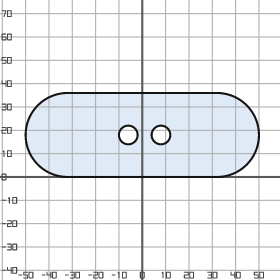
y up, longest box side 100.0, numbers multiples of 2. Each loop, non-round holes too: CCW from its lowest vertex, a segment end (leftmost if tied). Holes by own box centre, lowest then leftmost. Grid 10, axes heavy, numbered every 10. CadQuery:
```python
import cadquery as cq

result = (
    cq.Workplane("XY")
    .moveTo(-32.0, 0.0)
    .lineTo(32.0, 0.0)
    .threePointArc((50.0, 18.0), (32.0, 36.0))
    .lineTo(-32.0, 36.0)
    .threePointArc((-50.0, 18.0), (-32.0, 0.0))
    .close()
    .moveTo(-6.0, 18.0)
    .circle(4.0)
    .moveTo(8.0, 18.0)
    .circle(4.0)
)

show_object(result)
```